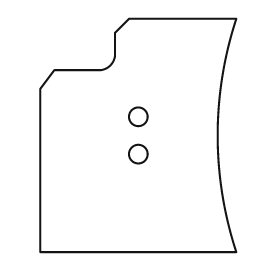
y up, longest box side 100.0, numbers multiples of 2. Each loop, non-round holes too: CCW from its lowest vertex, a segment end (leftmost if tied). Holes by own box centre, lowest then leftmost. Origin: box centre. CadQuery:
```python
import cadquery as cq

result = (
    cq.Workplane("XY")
    .moveTo(-42.0, -50.0)
    .lineTo(42.0, -50.0)
    .threePointArc((34.0, 0.0), (42.0, 50.0))
    .lineTo(-4.0, 50.0)
    .lineTo(-10.0, 44.0)
    .lineTo(-10.0, 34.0)
    .threePointArc((-12.0, 30.0), (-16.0, 28.0))
    .lineTo(-36.0, 28.0)
    .lineTo(-42.0, 20.0)
    .close()
    .moveTo(0.0, -8.0)
    .circle(4.0)
    .moveTo(0.0, 8.0)
    .circle(4.0)
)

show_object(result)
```